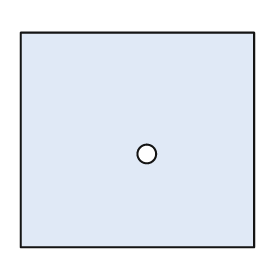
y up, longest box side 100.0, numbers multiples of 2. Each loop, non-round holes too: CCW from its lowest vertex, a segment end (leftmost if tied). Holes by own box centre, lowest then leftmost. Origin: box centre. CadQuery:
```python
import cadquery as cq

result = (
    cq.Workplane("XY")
    .moveTo(-50.0, -46.0)
    .lineTo(50.0, -46.0)
    .lineTo(50.0, 46.0)
    .lineTo(-50.0, 46.0)
    .close()
    .moveTo(4.0, -6.0)
    .circle(4.0)
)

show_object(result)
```